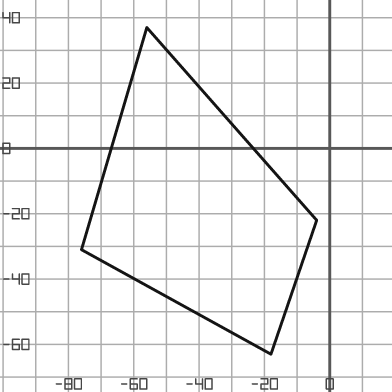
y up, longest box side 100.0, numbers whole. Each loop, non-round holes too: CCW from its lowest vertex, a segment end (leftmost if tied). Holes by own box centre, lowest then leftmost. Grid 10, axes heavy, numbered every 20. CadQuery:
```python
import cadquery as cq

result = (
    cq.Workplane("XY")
    .moveTo(-18.0, -63.0)
    .lineTo(-4.0, -22.0)
    .lineTo(-56.0, 37.0)
    .lineTo(-76.0, -31.0)
    .close()
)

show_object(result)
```